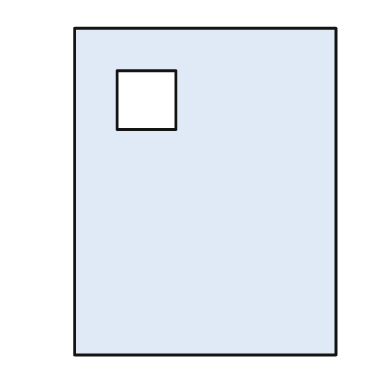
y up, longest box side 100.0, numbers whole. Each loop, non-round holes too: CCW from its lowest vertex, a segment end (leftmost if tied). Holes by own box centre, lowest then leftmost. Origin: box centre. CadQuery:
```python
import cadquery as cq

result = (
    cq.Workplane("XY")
    .moveTo(-40.0, -50.0)
    .lineTo(40.0, -50.0)
    .lineTo(40.0, 50.0)
    .lineTo(-40.0, 50.0)
    .close()
    .moveTo(-27.0, 19.0)
    .lineTo(-9.0, 19.0)
    .lineTo(-9.0, 37.0)
    .lineTo(-27.0, 37.0)
    .close()
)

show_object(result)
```